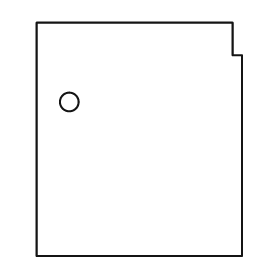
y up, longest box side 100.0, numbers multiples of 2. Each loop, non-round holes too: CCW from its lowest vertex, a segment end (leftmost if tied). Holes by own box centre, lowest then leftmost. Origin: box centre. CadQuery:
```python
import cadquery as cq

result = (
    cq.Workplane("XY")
    .moveTo(-44.0, -50.0)
    .lineTo(44.0, -50.0)
    .lineTo(44.0, 36.0)
    .lineTo(40.0, 36.0)
    .lineTo(40.0, 50.0)
    .lineTo(-44.0, 50.0)
    .close()
    .moveTo(-30.0, 16.0)
    .circle(4.0)
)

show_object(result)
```